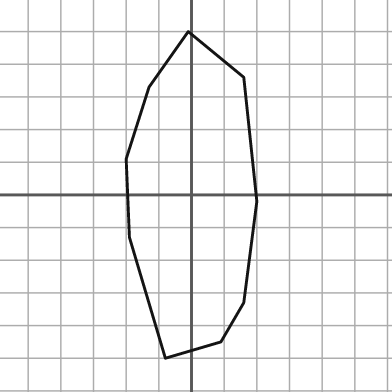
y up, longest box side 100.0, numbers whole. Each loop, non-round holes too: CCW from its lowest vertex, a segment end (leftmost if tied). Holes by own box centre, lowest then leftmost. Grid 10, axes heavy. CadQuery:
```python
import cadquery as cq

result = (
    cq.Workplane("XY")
    .moveTo(-8.0, -50.0)
    .lineTo(9.0, -45.0)
    .lineTo(16.0, -33.0)
    .lineTo(20.0, -2.0)
    .lineTo(16.0, 36.0)
    .lineTo(-1.0, 50.0)
    .lineTo(-13.0, 33.0)
    .lineTo(-20.0, 11.0)
    .lineTo(-19.0, -13.0)
    .close()
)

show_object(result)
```